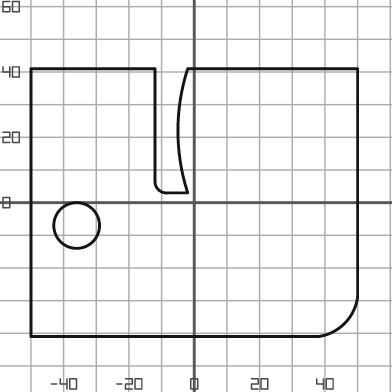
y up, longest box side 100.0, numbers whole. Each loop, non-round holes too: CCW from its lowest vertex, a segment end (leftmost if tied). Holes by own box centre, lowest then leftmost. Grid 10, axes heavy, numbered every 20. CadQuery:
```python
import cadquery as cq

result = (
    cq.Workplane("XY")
    .moveTo(-50.0, -41.0)
    .lineTo(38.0, -41.0)
    .threePointArc((46.0, -37.0), (50.0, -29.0))
    .lineTo(50.0, 41.0)
    .lineTo(-2.0, 41.0)
    .threePointArc((-5.0, 22.0), (-2.0, 3.0))
    .lineTo(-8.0, 3.0)
    .threePointArc((-11.0, 4.0), (-12.0, 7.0))
    .lineTo(-12.0, 41.0)
    .lineTo(-50.0, 41.0)
    .close()
    .moveTo(-36.0, -7.0)
    .circle(7.0)
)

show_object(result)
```